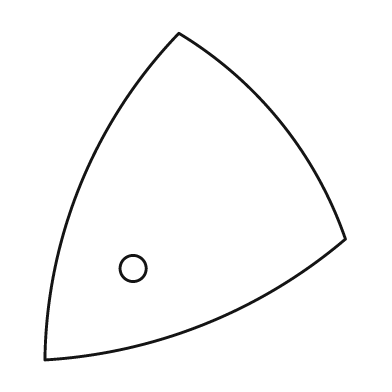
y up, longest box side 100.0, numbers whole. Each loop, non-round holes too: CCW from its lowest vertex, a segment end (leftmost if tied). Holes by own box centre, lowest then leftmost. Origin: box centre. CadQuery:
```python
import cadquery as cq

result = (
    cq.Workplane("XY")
    .moveTo(-46.0, -50.0)
    .threePointArc((3.0, -39.0), (46.0, -13.0))
    .threePointArc((26.0, 23.0), (-5.0, 50.0))
    .threePointArc((-35.0, 4.0), (-46.0, -50.0))
    .close()
    .moveTo(-19.0, -22.0)
    .circle(4.0)
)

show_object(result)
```